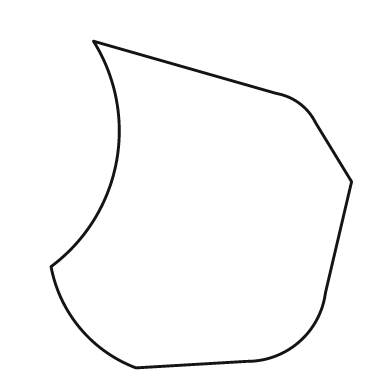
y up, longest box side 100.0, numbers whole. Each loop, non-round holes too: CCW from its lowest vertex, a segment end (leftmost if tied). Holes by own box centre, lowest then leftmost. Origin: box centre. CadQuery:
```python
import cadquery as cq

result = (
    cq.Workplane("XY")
    .moveTo(-20.0, -50.0)
    .lineTo(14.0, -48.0)
    .threePointArc((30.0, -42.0), (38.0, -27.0))
    .lineTo(46.0, 7.0)
    .lineTo(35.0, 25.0)
    .threePointArc((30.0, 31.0), (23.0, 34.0))
    .lineTo(-33.0, 50.0)
    .threePointArc((-26.0, 13.0), (-46.0, -19.0))
    .threePointArc((-37.0, -38.0), (-20.0, -50.0))
    .close()
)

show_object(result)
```